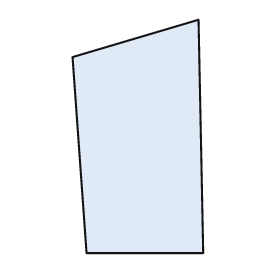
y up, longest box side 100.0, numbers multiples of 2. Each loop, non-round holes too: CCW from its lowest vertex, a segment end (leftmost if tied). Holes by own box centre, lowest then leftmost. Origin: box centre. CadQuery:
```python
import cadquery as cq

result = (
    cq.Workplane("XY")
    .moveTo(-22.0, -50.0)
    .lineTo(28.0, -50.0)
    .lineTo(26.0, 50.0)
    .lineTo(-28.0, 34.0)
    .close()
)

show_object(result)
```